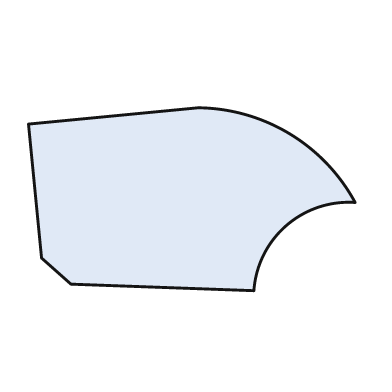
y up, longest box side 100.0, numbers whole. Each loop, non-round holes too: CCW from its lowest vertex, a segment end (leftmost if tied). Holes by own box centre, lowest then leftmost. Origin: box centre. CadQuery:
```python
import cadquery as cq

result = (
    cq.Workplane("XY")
    .moveTo(19.0, -28.0)
    .threePointArc((29.0, -8.0), (50.0, -1.0))
    .threePointArc((30.0, 20.0), (2.0, 28.0))
    .lineTo(-50.0, 23.0)
    .lineTo(-46.0, -18.0)
    .lineTo(-37.0, -26.0)
    .close()
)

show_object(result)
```